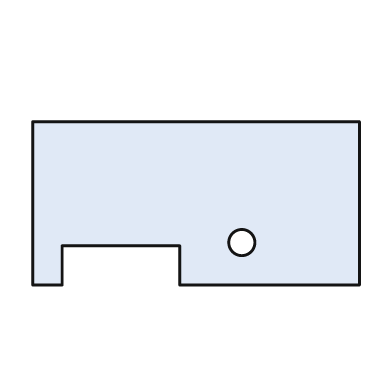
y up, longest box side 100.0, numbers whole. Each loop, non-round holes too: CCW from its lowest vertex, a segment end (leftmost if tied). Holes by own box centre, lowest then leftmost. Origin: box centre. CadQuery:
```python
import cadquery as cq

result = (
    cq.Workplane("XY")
    .moveTo(-50.0, -25.0)
    .lineTo(-41.0, -25.0)
    .lineTo(-41.0, -13.0)
    .lineTo(-5.0, -13.0)
    .lineTo(-5.0, -25.0)
    .lineTo(50.0, -25.0)
    .lineTo(50.0, 25.0)
    .lineTo(-50.0, 25.0)
    .close()
    .moveTo(14.0, -12.0)
    .circle(4.0)
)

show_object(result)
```